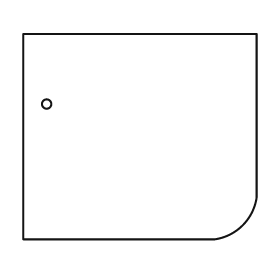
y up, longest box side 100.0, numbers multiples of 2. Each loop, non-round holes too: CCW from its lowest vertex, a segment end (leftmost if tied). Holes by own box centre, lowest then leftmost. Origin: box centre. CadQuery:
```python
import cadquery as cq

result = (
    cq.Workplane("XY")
    .moveTo(-50.0, -44.0)
    .lineTo(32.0, -44.0)
    .threePointArc((44.0, -38.0), (50.0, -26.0))
    .lineTo(50.0, 44.0)
    .lineTo(-50.0, 44.0)
    .close()
    .moveTo(-40.0, 14.0)
    .circle(2.0)
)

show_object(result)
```